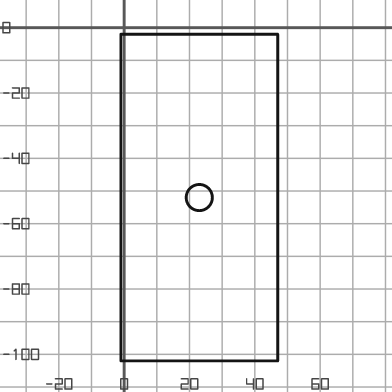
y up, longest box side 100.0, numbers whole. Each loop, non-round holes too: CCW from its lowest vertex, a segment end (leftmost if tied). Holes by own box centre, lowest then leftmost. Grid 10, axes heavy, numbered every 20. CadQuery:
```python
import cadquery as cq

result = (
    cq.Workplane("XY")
    .moveTo(-1.0, -102.0)
    .lineTo(47.0, -102.0)
    .lineTo(47.0, -2.0)
    .lineTo(-1.0, -2.0)
    .close()
    .moveTo(23.0, -52.0)
    .circle(4.0)
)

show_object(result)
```